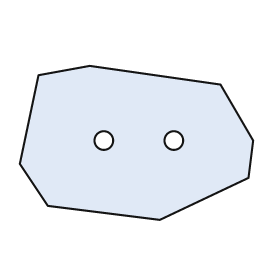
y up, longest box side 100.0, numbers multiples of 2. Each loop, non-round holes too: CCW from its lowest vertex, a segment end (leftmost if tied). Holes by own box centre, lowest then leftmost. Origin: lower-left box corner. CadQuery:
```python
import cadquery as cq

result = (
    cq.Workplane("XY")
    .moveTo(60.0, 0.0)
    .lineTo(98.0, 18.0)
    .lineTo(100.0, 34.0)
    .lineTo(86.0, 58.0)
    .lineTo(30.0, 66.0)
    .lineTo(8.0, 62.0)
    .lineTo(0.0, 24.0)
    .lineTo(12.0, 6.0)
    .close()
    .moveTo(36.0, 34.0)
    .circle(4.0)
    .moveTo(66.0, 34.0)
    .circle(4.0)
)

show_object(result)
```